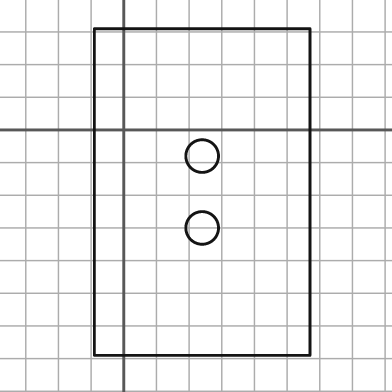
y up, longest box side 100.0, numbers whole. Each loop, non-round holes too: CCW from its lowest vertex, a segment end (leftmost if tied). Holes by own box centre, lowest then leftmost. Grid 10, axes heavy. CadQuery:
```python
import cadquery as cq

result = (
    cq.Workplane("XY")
    .moveTo(-9.0, -69.0)
    .lineTo(57.0, -69.0)
    .lineTo(57.0, 31.0)
    .lineTo(-9.0, 31.0)
    .close()
    .moveTo(24.0, -30.0)
    .circle(5.0)
    .moveTo(24.0, -8.0)
    .circle(5.0)
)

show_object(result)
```